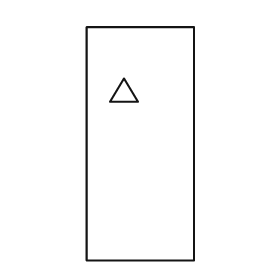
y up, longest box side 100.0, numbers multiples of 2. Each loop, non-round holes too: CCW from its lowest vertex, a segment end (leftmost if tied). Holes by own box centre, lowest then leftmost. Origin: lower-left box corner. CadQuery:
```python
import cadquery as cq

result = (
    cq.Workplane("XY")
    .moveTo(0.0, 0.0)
    .lineTo(46.0, 0.0)
    .lineTo(46.0, 100.0)
    .lineTo(0.0, 100.0)
    .close()
    .moveTo(10.0, 68.0)
    .lineTo(22.0, 68.0)
    .lineTo(16.0, 78.0)
    .close()
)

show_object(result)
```